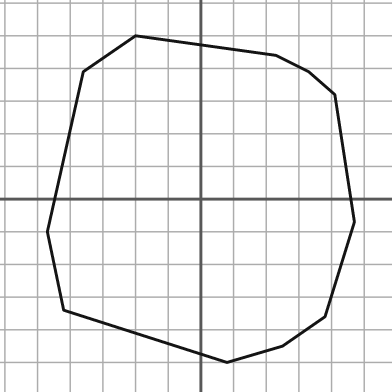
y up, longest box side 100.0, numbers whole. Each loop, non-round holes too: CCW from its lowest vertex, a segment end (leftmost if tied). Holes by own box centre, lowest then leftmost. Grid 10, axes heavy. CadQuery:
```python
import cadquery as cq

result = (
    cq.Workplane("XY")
    .moveTo(8.0, -50.0)
    .lineTo(25.0, -45.0)
    .lineTo(38.0, -36.0)
    .lineTo(47.0, -7.0)
    .lineTo(41.0, 32.0)
    .lineTo(33.0, 39.0)
    .lineTo(23.0, 44.0)
    .lineTo(-20.0, 50.0)
    .lineTo(-36.0, 39.0)
    .lineTo(-47.0, -10.0)
    .lineTo(-42.0, -34.0)
    .close()
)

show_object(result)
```